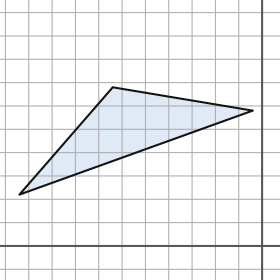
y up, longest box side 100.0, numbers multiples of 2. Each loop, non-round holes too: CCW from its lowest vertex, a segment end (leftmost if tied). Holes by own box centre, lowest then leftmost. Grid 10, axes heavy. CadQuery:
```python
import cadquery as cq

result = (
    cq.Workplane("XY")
    .moveTo(-104.0, 22.0)
    .lineTo(-4.0, 58.0)
    .lineTo(-64.0, 68.0)
    .close()
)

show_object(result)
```